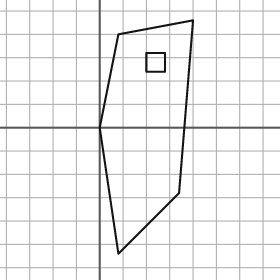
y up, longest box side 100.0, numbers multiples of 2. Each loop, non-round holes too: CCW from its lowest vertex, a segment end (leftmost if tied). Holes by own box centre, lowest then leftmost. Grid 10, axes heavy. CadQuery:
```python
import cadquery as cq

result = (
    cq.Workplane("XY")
    .moveTo(8.0, -54.0)
    .lineTo(34.0, -28.0)
    .lineTo(40.0, 46.0)
    .lineTo(8.0, 40.0)
    .lineTo(0.0, 0.0)
    .close()
    .moveTo(20.0, 24.0)
    .lineTo(28.0, 24.0)
    .lineTo(28.0, 32.0)
    .lineTo(20.0, 32.0)
    .close()
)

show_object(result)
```